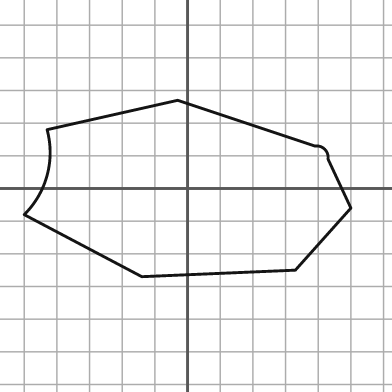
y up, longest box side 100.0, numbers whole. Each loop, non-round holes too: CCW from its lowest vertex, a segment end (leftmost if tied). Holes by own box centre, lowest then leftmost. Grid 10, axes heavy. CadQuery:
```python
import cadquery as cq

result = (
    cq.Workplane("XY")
    .moveTo(-14.0, -27.0)
    .lineTo(33.0, -25.0)
    .lineTo(50.0, -6.0)
    .lineTo(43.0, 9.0)
    .threePointArc((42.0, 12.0), (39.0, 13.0))
    .lineTo(-3.0, 27.0)
    .lineTo(-43.0, 18.0)
    .threePointArc((-43.0, 4.0), (-50.0, -8.0))
    .close()
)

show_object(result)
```